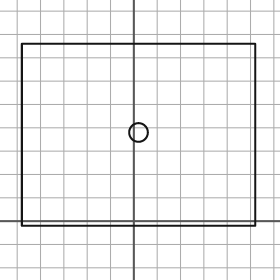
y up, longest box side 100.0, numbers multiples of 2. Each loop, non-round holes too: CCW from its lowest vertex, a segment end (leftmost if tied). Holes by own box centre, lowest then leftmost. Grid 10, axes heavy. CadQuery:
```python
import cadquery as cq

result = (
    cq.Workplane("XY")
    .moveTo(-48.0, -2.0)
    .lineTo(52.0, -2.0)
    .lineTo(52.0, 76.0)
    .lineTo(-48.0, 76.0)
    .close()
    .moveTo(2.0, 38.0)
    .circle(4.0)
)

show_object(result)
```